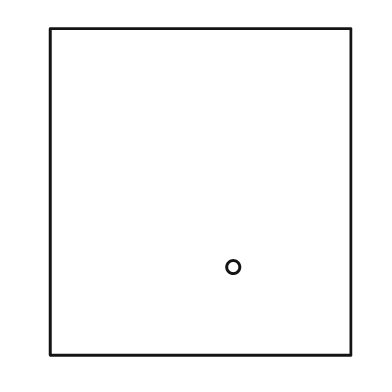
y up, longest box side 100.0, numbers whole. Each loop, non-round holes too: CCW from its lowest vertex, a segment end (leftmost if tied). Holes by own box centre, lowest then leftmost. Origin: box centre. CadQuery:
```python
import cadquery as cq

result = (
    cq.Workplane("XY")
    .moveTo(-46.0, -50.0)
    .lineTo(46.0, -50.0)
    .lineTo(46.0, 50.0)
    .lineTo(-46.0, 50.0)
    .close()
    .moveTo(10.0, -23.0)
    .circle(2.0)
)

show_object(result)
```